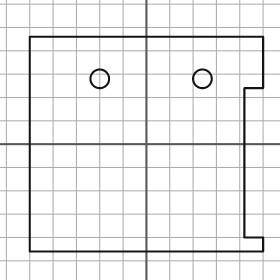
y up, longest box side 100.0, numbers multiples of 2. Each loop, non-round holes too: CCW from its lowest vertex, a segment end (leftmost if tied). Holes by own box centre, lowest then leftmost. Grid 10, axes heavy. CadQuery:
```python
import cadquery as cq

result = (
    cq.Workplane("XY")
    .moveTo(-50.0, -46.0)
    .lineTo(50.0, -46.0)
    .lineTo(50.0, -40.0)
    .lineTo(42.0, -40.0)
    .lineTo(42.0, 24.0)
    .lineTo(50.0, 24.0)
    .lineTo(50.0, 46.0)
    .lineTo(-50.0, 46.0)
    .close()
    .moveTo(-20.0, 28.0)
    .circle(4.0)
    .moveTo(24.0, 28.0)
    .circle(4.0)
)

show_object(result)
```